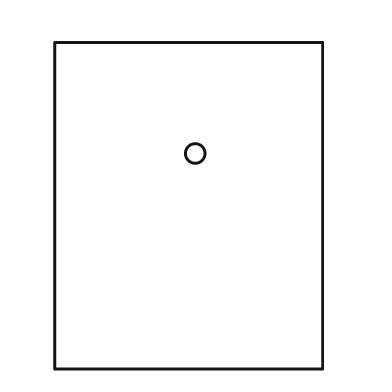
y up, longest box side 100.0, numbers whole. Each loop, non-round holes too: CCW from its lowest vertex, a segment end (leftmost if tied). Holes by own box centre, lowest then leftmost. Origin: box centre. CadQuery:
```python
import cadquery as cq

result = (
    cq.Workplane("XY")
    .moveTo(-41.0, -50.0)
    .lineTo(41.0, -50.0)
    .lineTo(41.0, 50.0)
    .lineTo(-41.0, 50.0)
    .close()
    .moveTo(2.0, 16.0)
    .circle(3.0)
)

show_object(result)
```